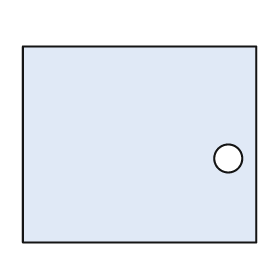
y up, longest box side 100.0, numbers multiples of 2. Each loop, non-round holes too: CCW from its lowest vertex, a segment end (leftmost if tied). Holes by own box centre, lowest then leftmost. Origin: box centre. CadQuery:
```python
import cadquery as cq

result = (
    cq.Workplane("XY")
    .moveTo(-50.0, -42.0)
    .lineTo(50.0, -42.0)
    .lineTo(50.0, 42.0)
    .lineTo(-50.0, 42.0)
    .close()
    .moveTo(38.0, -6.0)
    .circle(6.0)
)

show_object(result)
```